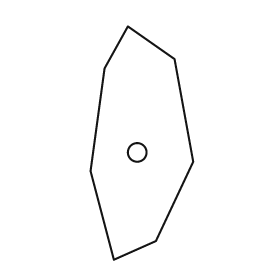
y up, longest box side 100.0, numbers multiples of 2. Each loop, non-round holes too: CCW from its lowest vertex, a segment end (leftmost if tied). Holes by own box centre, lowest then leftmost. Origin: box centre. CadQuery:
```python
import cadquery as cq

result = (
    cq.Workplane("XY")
    .moveTo(-12.0, -50.0)
    .lineTo(6.0, -42.0)
    .lineTo(22.0, -8.0)
    .lineTo(14.0, 36.0)
    .lineTo(-6.0, 50.0)
    .lineTo(-16.0, 32.0)
    .lineTo(-22.0, -12.0)
    .close()
    .moveTo(-2.0, -4.0)
    .circle(4.0)
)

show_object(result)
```